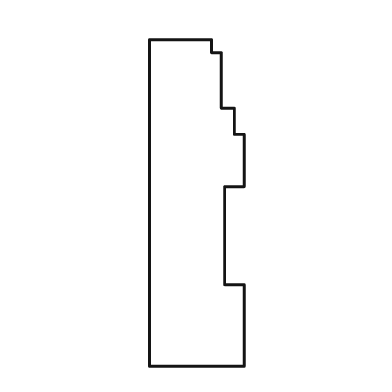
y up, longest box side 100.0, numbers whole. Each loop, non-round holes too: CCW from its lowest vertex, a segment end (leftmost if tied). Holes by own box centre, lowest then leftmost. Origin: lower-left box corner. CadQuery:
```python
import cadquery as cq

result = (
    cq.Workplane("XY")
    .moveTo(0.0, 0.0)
    .lineTo(29.0, 0.0)
    .lineTo(29.0, 25.0)
    .lineTo(23.0, 25.0)
    .lineTo(23.0, 55.0)
    .lineTo(29.0, 55.0)
    .lineTo(29.0, 71.0)
    .lineTo(26.0, 71.0)
    .lineTo(26.0, 79.0)
    .lineTo(22.0, 79.0)
    .lineTo(22.0, 96.0)
    .lineTo(19.0, 96.0)
    .lineTo(19.0, 100.0)
    .lineTo(0.0, 100.0)
    .close()
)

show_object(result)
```